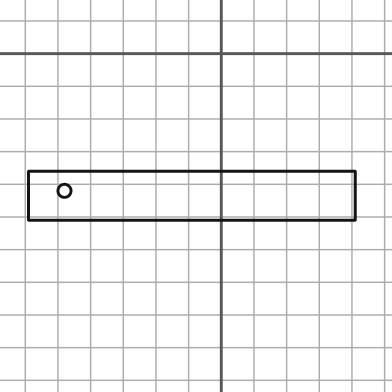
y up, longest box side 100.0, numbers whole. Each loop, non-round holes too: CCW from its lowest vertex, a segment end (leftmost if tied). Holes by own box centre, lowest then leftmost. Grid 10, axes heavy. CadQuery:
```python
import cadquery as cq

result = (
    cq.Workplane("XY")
    .moveTo(-59.0, -51.0)
    .lineTo(41.0, -51.0)
    .lineTo(41.0, -36.0)
    .lineTo(-59.0, -36.0)
    .close()
    .moveTo(-48.0, -42.0)
    .circle(2.0)
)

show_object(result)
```